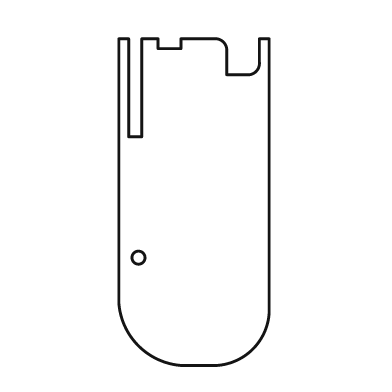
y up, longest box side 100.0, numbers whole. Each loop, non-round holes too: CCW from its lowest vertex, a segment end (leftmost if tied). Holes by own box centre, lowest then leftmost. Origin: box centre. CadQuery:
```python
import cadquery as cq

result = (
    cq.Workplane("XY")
    .moveTo(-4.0, -50.0)
    .lineTo(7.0, -50.0)
    .threePointArc((18.0, -45.0), (23.0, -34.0))
    .lineTo(23.0, 50.0)
    .lineTo(20.0, 50.0)
    .lineTo(20.0, 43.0)
    .threePointArc((19.0, 40.0), (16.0, 39.0))
    .lineTo(10.0, 39.0)
    .lineTo(10.0, 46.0)
    .threePointArc((9.0, 49.0), (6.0, 50.0))
    .lineTo(-4.0, 50.0)
    .lineTo(-4.0, 47.0)
    .lineTo(-11.0, 47.0)
    .lineTo(-11.0, 50.0)
    .lineTo(-16.0, 50.0)
    .lineTo(-16.0, 20.0)
    .lineTo(-20.0, 20.0)
    .lineTo(-20.0, 50.0)
    .lineTo(-23.0, 50.0)
    .lineTo(-23.0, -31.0)
    .threePointArc((-17.0, -44.0), (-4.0, -50.0))
    .close()
    .moveTo(-17.0, -17.0)
    .circle(2.0)
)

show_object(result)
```